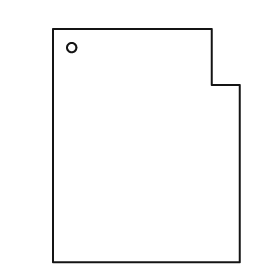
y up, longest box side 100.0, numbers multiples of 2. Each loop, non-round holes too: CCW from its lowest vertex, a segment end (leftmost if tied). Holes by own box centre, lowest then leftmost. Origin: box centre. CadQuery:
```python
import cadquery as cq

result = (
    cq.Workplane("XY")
    .moveTo(-40.0, -50.0)
    .lineTo(40.0, -50.0)
    .lineTo(40.0, 26.0)
    .lineTo(28.0, 26.0)
    .lineTo(28.0, 50.0)
    .lineTo(-40.0, 50.0)
    .close()
    .moveTo(-32.0, 42.0)
    .circle(2.0)
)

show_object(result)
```